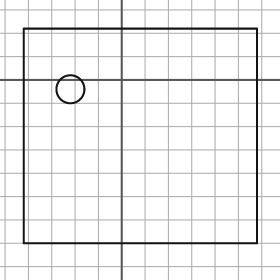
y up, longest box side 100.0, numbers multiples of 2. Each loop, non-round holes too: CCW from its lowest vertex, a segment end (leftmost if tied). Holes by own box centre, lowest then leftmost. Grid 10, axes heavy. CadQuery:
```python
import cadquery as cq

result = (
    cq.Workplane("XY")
    .moveTo(-42.0, -70.0)
    .lineTo(58.0, -70.0)
    .lineTo(58.0, 22.0)
    .lineTo(-42.0, 22.0)
    .close()
    .moveTo(-22.0, -4.0)
    .circle(6.0)
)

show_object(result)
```